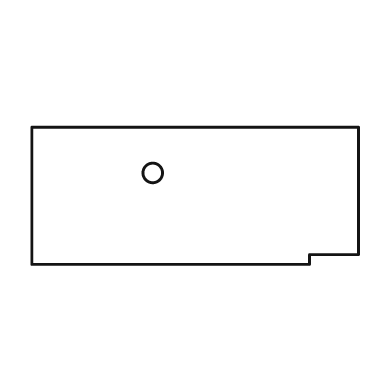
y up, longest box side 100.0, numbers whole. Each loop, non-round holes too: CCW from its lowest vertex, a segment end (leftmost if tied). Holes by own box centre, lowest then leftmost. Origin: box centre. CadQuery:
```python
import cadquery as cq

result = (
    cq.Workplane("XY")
    .moveTo(-50.0, -21.0)
    .lineTo(35.0, -21.0)
    .lineTo(35.0, -18.0)
    .lineTo(50.0, -18.0)
    .lineTo(50.0, 21.0)
    .lineTo(-50.0, 21.0)
    .close()
    .moveTo(-13.0, 7.0)
    .circle(3.0)
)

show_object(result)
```